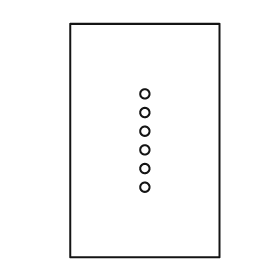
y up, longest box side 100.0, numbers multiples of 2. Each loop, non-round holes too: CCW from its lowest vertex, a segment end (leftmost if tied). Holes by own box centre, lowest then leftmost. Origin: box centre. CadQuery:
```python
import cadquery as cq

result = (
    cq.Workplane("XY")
    .moveTo(-32.0, -50.0)
    .lineTo(32.0, -50.0)
    .lineTo(32.0, 50.0)
    .lineTo(-32.0, 50.0)
    .close()
    .moveTo(0.0, -20.0)
    .circle(2.0)
    .moveTo(0.0, -12.0)
    .circle(2.0)
    .moveTo(0.0, -4.0)
    .circle(2.0)
    .moveTo(0.0, 4.0)
    .circle(2.0)
    .moveTo(0.0, 12.0)
    .circle(2.0)
    .moveTo(0.0, 20.0)
    .circle(2.0)
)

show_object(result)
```